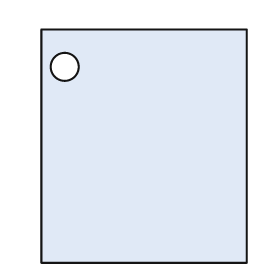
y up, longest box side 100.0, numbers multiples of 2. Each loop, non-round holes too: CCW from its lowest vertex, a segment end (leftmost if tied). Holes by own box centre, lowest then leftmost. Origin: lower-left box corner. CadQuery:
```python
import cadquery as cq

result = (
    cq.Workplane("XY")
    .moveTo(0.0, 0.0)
    .lineTo(88.0, 0.0)
    .lineTo(88.0, 100.0)
    .lineTo(0.0, 100.0)
    .close()
    .moveTo(10.0, 84.0)
    .circle(6.0)
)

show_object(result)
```